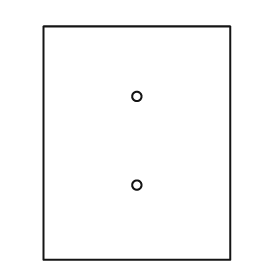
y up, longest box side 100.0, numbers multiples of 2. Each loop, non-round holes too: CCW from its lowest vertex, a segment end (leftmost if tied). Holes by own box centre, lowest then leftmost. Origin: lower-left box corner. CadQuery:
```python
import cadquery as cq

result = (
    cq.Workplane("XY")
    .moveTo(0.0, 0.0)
    .lineTo(80.0, 0.0)
    .lineTo(80.0, 100.0)
    .lineTo(0.0, 100.0)
    .close()
    .moveTo(40.0, 32.0)
    .circle(2.0)
    .moveTo(40.0, 70.0)
    .circle(2.0)
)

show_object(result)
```